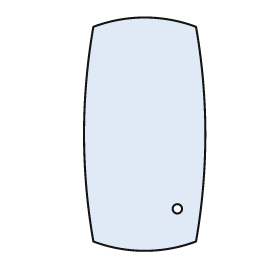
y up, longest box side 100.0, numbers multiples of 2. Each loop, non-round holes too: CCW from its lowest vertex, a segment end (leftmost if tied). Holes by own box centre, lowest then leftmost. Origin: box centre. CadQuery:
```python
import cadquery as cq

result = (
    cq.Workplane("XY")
    .moveTo(-22.0, -46.0)
    .threePointArc((0.0, -50.0), (22.0, -46.0))
    .threePointArc((26.0, 0.0), (22.0, 46.0))
    .threePointArc((0.0, 50.0), (-22.0, 46.0))
    .threePointArc((-26.0, 0.0), (-22.0, -46.0))
    .close()
    .moveTo(14.0, -32.0)
    .circle(2.0)
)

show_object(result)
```